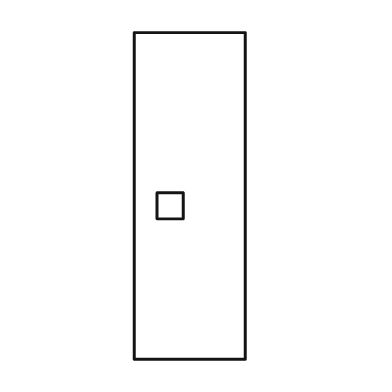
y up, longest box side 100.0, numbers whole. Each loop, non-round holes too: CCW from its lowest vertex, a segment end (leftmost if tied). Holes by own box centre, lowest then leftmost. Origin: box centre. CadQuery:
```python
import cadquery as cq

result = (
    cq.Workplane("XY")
    .moveTo(-17.0, -50.0)
    .lineTo(17.0, -50.0)
    .lineTo(17.0, 50.0)
    .lineTo(-17.0, 50.0)
    .close()
    .moveTo(-10.0, -7.0)
    .lineTo(-2.0, -7.0)
    .lineTo(-2.0, 1.0)
    .lineTo(-10.0, 1.0)
    .close()
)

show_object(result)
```